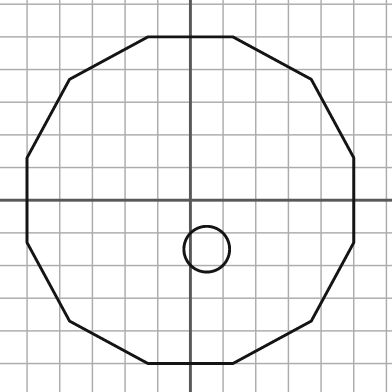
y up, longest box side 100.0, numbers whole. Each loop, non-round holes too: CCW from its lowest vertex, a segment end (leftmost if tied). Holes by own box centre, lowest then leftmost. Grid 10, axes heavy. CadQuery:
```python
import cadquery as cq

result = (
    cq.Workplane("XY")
    .moveTo(-13.0, -50.0)
    .lineTo(13.0, -50.0)
    .lineTo(37.0, -37.0)
    .lineTo(50.0, -13.0)
    .lineTo(50.0, 13.0)
    .lineTo(37.0, 37.0)
    .lineTo(13.0, 50.0)
    .lineTo(-13.0, 50.0)
    .lineTo(-37.0, 37.0)
    .lineTo(-50.0, 13.0)
    .lineTo(-50.0, -13.0)
    .lineTo(-37.0, -37.0)
    .close()
    .moveTo(5.0, -15.0)
    .circle(7.0)
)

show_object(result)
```